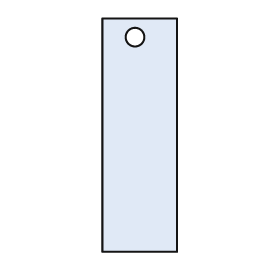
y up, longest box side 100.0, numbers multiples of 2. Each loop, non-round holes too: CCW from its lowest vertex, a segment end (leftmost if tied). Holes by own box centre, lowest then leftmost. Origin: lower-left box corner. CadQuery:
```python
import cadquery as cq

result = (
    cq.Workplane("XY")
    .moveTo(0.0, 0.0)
    .lineTo(32.0, 0.0)
    .lineTo(32.0, 100.0)
    .lineTo(0.0, 100.0)
    .close()
    .moveTo(14.0, 92.0)
    .circle(4.0)
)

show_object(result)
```